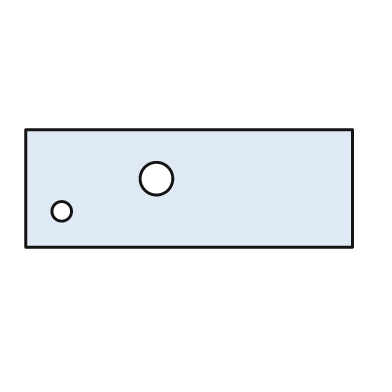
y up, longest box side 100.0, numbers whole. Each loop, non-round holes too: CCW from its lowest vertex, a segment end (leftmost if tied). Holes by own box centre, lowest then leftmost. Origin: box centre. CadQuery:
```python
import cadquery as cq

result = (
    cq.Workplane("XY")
    .moveTo(-50.0, -18.0)
    .lineTo(50.0, -18.0)
    .lineTo(50.0, 18.0)
    .lineTo(-50.0, 18.0)
    .close()
    .moveTo(-39.0, -7.0)
    .circle(3.0)
    .moveTo(-10.0, 3.0)
    .circle(5.0)
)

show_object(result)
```